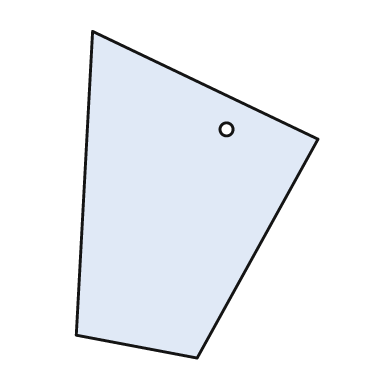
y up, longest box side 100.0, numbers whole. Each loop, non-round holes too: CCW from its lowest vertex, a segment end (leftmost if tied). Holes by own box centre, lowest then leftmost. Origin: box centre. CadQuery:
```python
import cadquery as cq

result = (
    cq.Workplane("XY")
    .moveTo(0.0, -50.0)
    .lineTo(37.0, 17.0)
    .lineTo(-32.0, 50.0)
    .lineTo(-37.0, -43.0)
    .close()
    .moveTo(9.0, 20.0)
    .circle(2.0)
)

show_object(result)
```